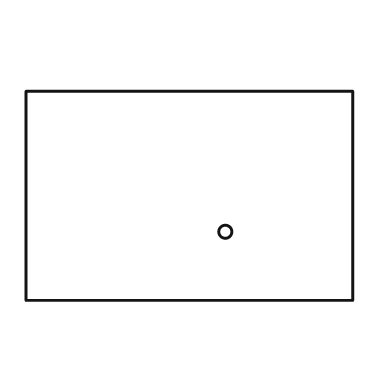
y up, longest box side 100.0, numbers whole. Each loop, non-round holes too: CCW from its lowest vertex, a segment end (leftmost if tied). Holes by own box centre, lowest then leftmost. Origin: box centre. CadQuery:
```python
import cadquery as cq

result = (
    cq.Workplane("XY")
    .moveTo(-50.0, -32.0)
    .lineTo(50.0, -32.0)
    .lineTo(50.0, 32.0)
    .lineTo(-50.0, 32.0)
    .close()
    .moveTo(11.0, -11.0)
    .circle(2.0)
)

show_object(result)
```